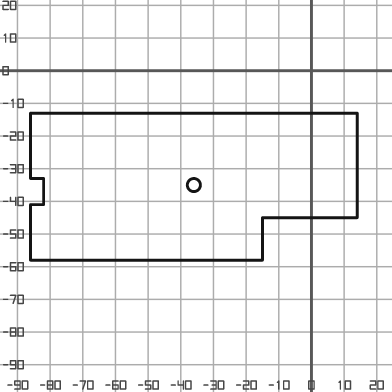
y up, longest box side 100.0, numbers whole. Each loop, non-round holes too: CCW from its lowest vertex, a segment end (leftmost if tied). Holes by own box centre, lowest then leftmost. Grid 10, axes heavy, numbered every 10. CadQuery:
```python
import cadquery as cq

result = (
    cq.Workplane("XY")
    .moveTo(-86.0, -58.0)
    .lineTo(-15.0, -58.0)
    .lineTo(-15.0, -45.0)
    .lineTo(14.0, -45.0)
    .lineTo(14.0, -13.0)
    .lineTo(-86.0, -13.0)
    .lineTo(-86.0, -33.0)
    .lineTo(-82.0, -33.0)
    .lineTo(-82.0, -41.0)
    .lineTo(-86.0, -41.0)
    .close()
    .moveTo(-36.0, -35.0)
    .circle(2.0)
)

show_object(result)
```